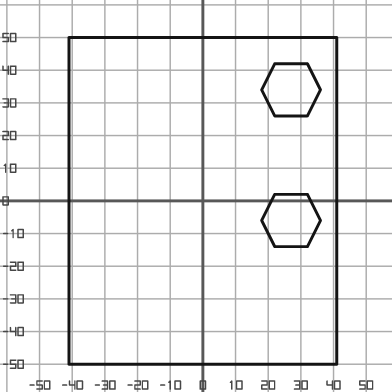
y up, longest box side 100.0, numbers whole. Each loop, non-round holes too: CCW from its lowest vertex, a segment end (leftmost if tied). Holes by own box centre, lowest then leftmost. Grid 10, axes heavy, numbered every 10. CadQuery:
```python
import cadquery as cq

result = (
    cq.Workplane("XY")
    .moveTo(-41.0, -50.0)
    .lineTo(41.0, -50.0)
    .lineTo(41.0, 50.0)
    .lineTo(-41.0, 50.0)
    .close()
    .moveTo(22.0, -14.0)
    .lineTo(32.0, -14.0)
    .lineTo(36.0, -6.0)
    .lineTo(32.0, 2.0)
    .lineTo(22.0, 2.0)
    .lineTo(18.0, -6.0)
    .close()
    .moveTo(22.0, 26.0)
    .lineTo(32.0, 26.0)
    .lineTo(36.0, 34.0)
    .lineTo(32.0, 42.0)
    .lineTo(22.0, 42.0)
    .lineTo(18.0, 34.0)
    .close()
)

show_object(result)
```